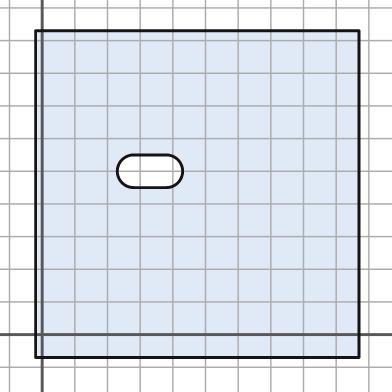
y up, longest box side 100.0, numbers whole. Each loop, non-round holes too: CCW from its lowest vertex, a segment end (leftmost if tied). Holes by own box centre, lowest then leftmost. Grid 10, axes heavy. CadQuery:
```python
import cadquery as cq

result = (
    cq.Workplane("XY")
    .moveTo(-2.0, -7.0)
    .lineTo(97.0, -7.0)
    .lineTo(97.0, 93.0)
    .lineTo(-2.0, 93.0)
    .close()
    .moveTo(28.0, 45.0)
    .lineTo(38.0, 45.0)
    .threePointArc((43.0, 50.0), (38.0, 55.0))
    .lineTo(28.0, 55.0)
    .threePointArc((23.0, 50.0), (28.0, 45.0))
    .close()
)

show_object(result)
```